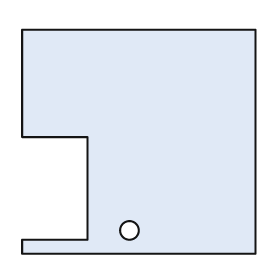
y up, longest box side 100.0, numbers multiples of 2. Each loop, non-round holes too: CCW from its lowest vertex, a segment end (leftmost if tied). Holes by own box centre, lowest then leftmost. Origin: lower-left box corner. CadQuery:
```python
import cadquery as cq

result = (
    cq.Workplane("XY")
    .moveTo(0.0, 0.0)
    .lineTo(100.0, 0.0)
    .lineTo(100.0, 96.0)
    .lineTo(0.0, 96.0)
    .lineTo(0.0, 50.0)
    .lineTo(28.0, 50.0)
    .lineTo(28.0, 6.0)
    .lineTo(0.0, 6.0)
    .close()
    .moveTo(46.0, 10.0)
    .circle(4.0)
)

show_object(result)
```